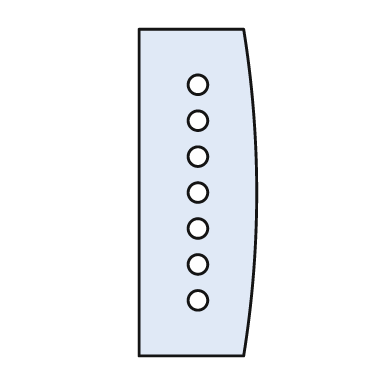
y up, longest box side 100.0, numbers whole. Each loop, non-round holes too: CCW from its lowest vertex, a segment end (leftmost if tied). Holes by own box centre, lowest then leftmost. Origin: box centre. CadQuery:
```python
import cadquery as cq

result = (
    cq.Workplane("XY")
    .moveTo(-18.0, -50.0)
    .lineTo(14.0, -50.0)
    .threePointArc((18.0, 0.0), (14.0, 50.0))
    .lineTo(-18.0, 50.0)
    .close()
    .moveTo(0.0, -33.0)
    .circle(3.0)
    .moveTo(0.0, -22.0)
    .circle(3.0)
    .moveTo(0.0, -11.0)
    .circle(3.0)
    .moveTo(0.0, 0.0)
    .circle(3.0)
    .moveTo(0.0, 11.0)
    .circle(3.0)
    .moveTo(0.0, 22.0)
    .circle(3.0)
    .moveTo(0.0, 33.0)
    .circle(3.0)
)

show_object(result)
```